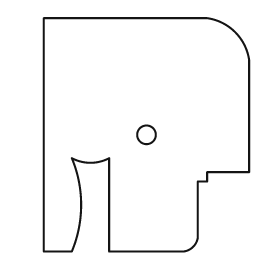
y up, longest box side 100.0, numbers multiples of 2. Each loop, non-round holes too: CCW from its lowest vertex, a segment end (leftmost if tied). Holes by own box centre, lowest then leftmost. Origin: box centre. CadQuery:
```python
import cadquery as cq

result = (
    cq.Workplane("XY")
    .moveTo(-44.0, -50.0)
    .lineTo(-32.0, -50.0)
    .threePointArc((-28.0, -30.0), (-32.0, -10.0))
    .threePointArc((-24.0, -12.0), (-16.0, -10.0))
    .lineTo(-16.0, -50.0)
    .lineTo(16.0, -50.0)
    .threePointArc((20.0, -48.0), (22.0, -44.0))
    .lineTo(22.0, -20.0)
    .lineTo(26.0, -20.0)
    .lineTo(26.0, -16.0)
    .lineTo(44.0, -16.0)
    .lineTo(44.0, 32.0)
    .threePointArc((38.0, 44.0), (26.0, 50.0))
    .lineTo(-44.0, 50.0)
    .close()
    .moveTo(0.0, 0.0)
    .circle(4.0)
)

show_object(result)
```